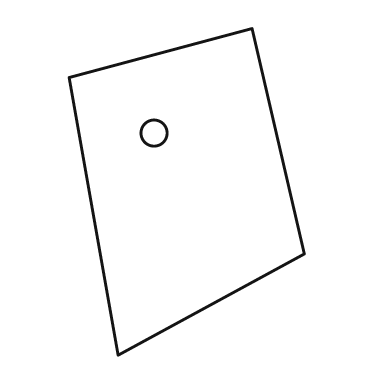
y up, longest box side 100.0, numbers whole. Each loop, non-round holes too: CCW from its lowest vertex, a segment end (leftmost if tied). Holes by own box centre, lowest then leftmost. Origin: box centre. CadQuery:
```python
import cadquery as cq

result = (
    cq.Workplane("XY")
    .moveTo(-21.0, -50.0)
    .lineTo(36.0, -19.0)
    .lineTo(20.0, 50.0)
    .lineTo(-36.0, 35.0)
    .close()
    .moveTo(-10.0, 18.0)
    .circle(4.0)
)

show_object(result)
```